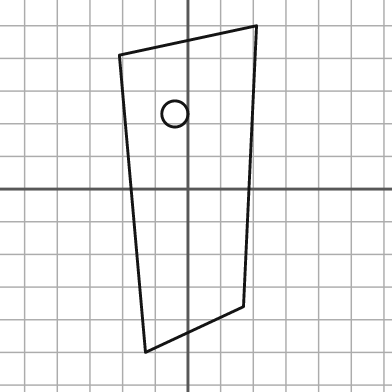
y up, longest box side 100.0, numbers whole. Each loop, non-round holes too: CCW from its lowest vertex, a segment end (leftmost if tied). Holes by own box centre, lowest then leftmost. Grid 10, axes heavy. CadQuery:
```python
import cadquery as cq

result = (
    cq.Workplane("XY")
    .moveTo(-13.0, -50.0)
    .lineTo(17.0, -36.0)
    .lineTo(21.0, 50.0)
    .lineTo(-21.0, 41.0)
    .close()
    .moveTo(-4.0, 23.0)
    .circle(4.0)
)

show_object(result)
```